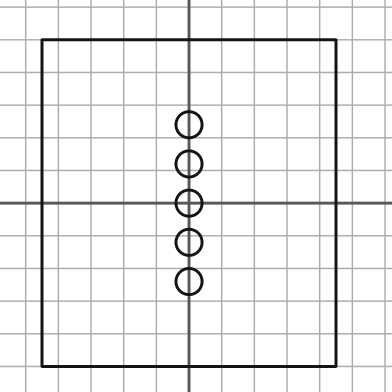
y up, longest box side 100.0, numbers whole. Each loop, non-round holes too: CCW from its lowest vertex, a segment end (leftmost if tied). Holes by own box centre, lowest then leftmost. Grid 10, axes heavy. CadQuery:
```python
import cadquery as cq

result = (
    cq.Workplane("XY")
    .moveTo(-45.0, -50.0)
    .lineTo(45.0, -50.0)
    .lineTo(45.0, 50.0)
    .lineTo(-45.0, 50.0)
    .close()
    .moveTo(0.0, -24.0)
    .circle(4.0)
    .moveTo(0.0, -12.0)
    .circle(4.0)
    .moveTo(0.0, 0.0)
    .circle(4.0)
    .moveTo(0.0, 12.0)
    .circle(4.0)
    .moveTo(0.0, 24.0)
    .circle(4.0)
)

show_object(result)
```